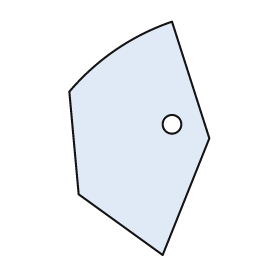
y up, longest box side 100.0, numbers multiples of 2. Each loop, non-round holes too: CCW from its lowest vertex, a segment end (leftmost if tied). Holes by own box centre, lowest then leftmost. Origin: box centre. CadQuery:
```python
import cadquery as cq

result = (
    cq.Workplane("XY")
    .moveTo(10.0, -50.0)
    .lineTo(30.0, 0.0)
    .lineTo(14.0, 50.0)
    .threePointArc((-10.0, 38.0), (-30.0, 20.0))
    .lineTo(-26.0, -24.0)
    .close()
    .moveTo(14.0, 6.0)
    .circle(4.0)
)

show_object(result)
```